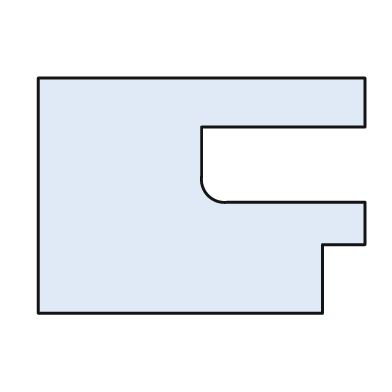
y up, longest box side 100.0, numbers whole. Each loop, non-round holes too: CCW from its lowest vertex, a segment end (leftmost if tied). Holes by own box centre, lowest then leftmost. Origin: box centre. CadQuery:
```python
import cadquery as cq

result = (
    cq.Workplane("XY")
    .moveTo(-50.0, -36.0)
    .lineTo(37.0, -36.0)
    .lineTo(37.0, -15.0)
    .lineTo(50.0, -15.0)
    .lineTo(50.0, -2.0)
    .lineTo(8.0, -2.0)
    .threePointArc((2.0, 0.0), (0.0, 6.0))
    .lineTo(0.0, 21.0)
    .lineTo(50.0, 21.0)
    .lineTo(50.0, 36.0)
    .lineTo(-50.0, 36.0)
    .close()
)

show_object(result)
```